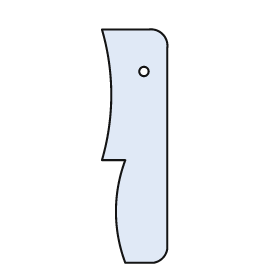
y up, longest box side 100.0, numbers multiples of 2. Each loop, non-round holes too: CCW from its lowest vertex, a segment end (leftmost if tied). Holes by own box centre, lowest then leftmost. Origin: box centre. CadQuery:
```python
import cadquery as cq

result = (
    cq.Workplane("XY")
    .moveTo(-4.0, -50.0)
    .lineTo(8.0, -50.0)
    .threePointArc((12.0, -48.0), (14.0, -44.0))
    .lineTo(14.0, 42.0)
    .threePointArc((12.0, 48.0), (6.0, 50.0))
    .lineTo(-14.0, 50.0)
    .threePointArc((-10.0, 22.0), (-14.0, -6.0))
    .lineTo(-4.0, -6.0)
    .threePointArc((-8.0, -28.0), (-4.0, -50.0))
    .close()
    .moveTo(4.0, 32.0)
    .circle(2.0)
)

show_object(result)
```